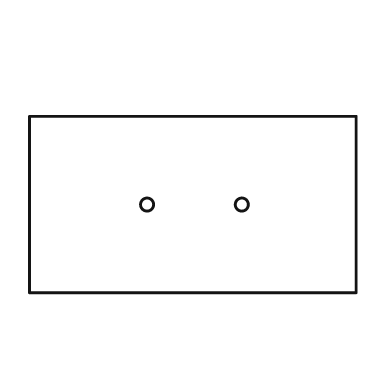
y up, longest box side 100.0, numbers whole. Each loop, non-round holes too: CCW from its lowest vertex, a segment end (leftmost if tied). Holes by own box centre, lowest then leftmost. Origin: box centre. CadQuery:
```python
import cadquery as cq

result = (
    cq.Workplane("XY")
    .moveTo(-50.0, -27.0)
    .lineTo(50.0, -27.0)
    .lineTo(50.0, 27.0)
    .lineTo(-50.0, 27.0)
    .close()
    .moveTo(-14.0, 0.0)
    .circle(2.0)
    .moveTo(15.0, 0.0)
    .circle(2.0)
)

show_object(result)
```